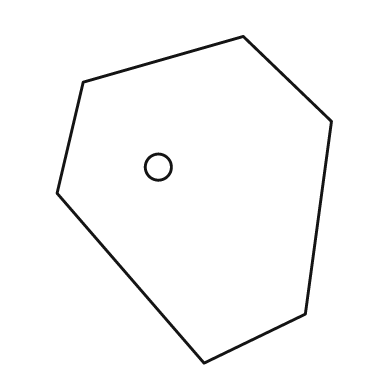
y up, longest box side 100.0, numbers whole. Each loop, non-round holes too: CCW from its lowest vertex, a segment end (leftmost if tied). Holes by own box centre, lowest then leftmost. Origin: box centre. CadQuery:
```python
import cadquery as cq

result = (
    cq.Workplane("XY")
    .moveTo(3.0, -50.0)
    .lineTo(34.0, -35.0)
    .lineTo(42.0, 24.0)
    .lineTo(15.0, 50.0)
    .lineTo(-34.0, 36.0)
    .lineTo(-42.0, 2.0)
    .close()
    .moveTo(-11.0, 10.0)
    .circle(4.0)
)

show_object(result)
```